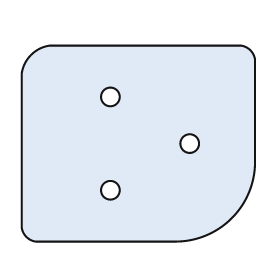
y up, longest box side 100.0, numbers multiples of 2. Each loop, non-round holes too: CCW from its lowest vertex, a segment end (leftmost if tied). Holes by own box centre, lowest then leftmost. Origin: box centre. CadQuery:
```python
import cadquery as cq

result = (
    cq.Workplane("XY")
    .moveTo(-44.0, -42.0)
    .lineTo(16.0, -42.0)
    .threePointArc((40.0, -32.0), (50.0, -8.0))
    .lineTo(50.0, 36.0)
    .threePointArc((48.0, 40.0), (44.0, 42.0))
    .lineTo(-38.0, 42.0)
    .threePointArc((-46.0, 38.0), (-50.0, 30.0))
    .lineTo(-50.0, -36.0)
    .threePointArc((-48.0, -40.0), (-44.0, -42.0))
    .close()
    .moveTo(-12.0, -20.0)
    .circle(4.0)
    .moveTo(22.0, 0.0)
    .circle(4.0)
    .moveTo(-12.0, 20.0)
    .circle(4.0)
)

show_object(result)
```